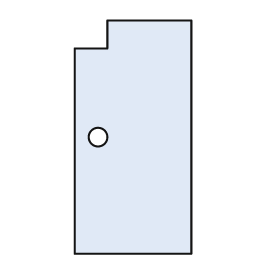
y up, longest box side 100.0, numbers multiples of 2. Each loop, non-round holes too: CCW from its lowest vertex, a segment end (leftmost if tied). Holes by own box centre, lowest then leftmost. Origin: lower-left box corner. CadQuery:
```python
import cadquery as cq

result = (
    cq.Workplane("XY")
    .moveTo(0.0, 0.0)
    .lineTo(50.0, 0.0)
    .lineTo(50.0, 100.0)
    .lineTo(14.0, 100.0)
    .lineTo(14.0, 88.0)
    .lineTo(0.0, 88.0)
    .close()
    .moveTo(10.0, 50.0)
    .circle(4.0)
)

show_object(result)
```